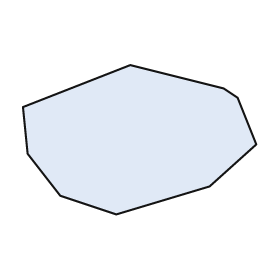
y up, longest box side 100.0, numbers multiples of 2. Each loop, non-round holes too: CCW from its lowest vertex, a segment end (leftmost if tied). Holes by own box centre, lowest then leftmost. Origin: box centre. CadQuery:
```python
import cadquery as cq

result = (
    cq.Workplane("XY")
    .moveTo(-10.0, -32.0)
    .lineTo(30.0, -20.0)
    .lineTo(50.0, -2.0)
    .lineTo(42.0, 18.0)
    .lineTo(36.0, 22.0)
    .lineTo(-4.0, 32.0)
    .lineTo(-50.0, 14.0)
    .lineTo(-48.0, -6.0)
    .lineTo(-34.0, -24.0)
    .close()
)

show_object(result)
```